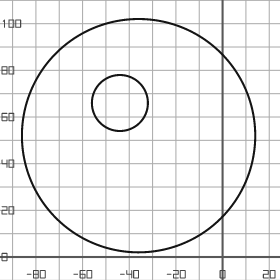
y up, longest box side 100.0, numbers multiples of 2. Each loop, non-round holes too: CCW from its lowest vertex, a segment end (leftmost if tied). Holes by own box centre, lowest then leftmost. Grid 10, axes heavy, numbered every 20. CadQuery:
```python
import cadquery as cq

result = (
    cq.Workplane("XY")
    .moveTo(-36.0, 52.0)
    .circle(50.0)
    .moveTo(-44.0, 66.0)
    .circle(12.0)
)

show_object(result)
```